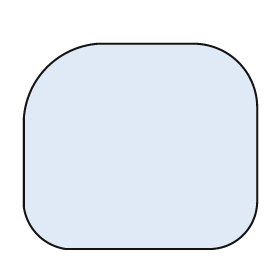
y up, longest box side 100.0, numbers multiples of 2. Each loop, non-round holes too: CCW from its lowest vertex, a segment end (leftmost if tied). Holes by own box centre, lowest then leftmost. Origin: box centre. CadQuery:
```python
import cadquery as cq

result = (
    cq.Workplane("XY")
    .moveTo(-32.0, -44.0)
    .lineTo(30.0, -44.0)
    .threePointArc((44.0, -38.0), (50.0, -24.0))
    .lineTo(50.0, 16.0)
    .threePointArc((42.0, 36.0), (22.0, 44.0))
    .lineTo(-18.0, 44.0)
    .threePointArc((-40.0, 34.0), (-50.0, 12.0))
    .lineTo(-50.0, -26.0)
    .threePointArc((-44.0, -38.0), (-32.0, -44.0))
    .close()
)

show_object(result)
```